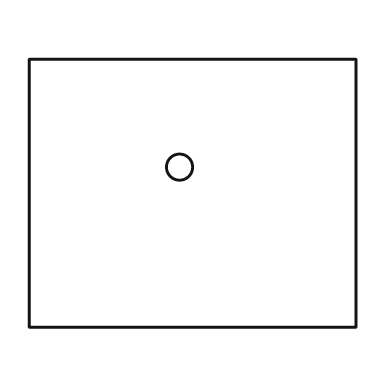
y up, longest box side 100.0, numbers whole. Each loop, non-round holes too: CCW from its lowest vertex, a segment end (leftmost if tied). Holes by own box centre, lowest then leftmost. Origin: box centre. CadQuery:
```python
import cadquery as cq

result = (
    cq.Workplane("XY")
    .moveTo(-50.0, -41.0)
    .lineTo(50.0, -41.0)
    .lineTo(50.0, 41.0)
    .lineTo(-50.0, 41.0)
    .close()
    .moveTo(-4.0, 8.0)
    .circle(4.0)
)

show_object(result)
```